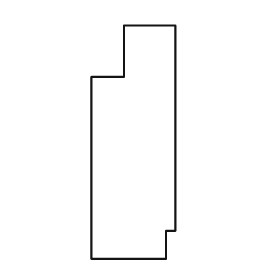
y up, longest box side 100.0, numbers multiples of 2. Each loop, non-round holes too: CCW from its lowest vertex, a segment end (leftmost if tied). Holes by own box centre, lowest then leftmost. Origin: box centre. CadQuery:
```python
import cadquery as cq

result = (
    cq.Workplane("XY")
    .moveTo(-18.0, -50.0)
    .lineTo(14.0, -50.0)
    .lineTo(14.0, -38.0)
    .lineTo(18.0, -38.0)
    .lineTo(18.0, 50.0)
    .lineTo(-4.0, 50.0)
    .lineTo(-4.0, 28.0)
    .lineTo(-18.0, 28.0)
    .close()
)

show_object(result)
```